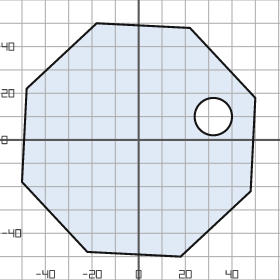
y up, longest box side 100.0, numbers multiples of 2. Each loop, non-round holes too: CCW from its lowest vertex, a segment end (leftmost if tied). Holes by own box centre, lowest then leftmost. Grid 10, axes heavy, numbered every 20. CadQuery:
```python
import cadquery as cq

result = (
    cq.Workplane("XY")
    .moveTo(18.0, -50.0)
    .lineTo(48.0, -22.0)
    .lineTo(50.0, 18.0)
    .lineTo(22.0, 48.0)
    .lineTo(-18.0, 50.0)
    .lineTo(-48.0, 22.0)
    .lineTo(-50.0, -18.0)
    .lineTo(-22.0, -48.0)
    .close()
    .moveTo(32.0, 10.0)
    .circle(8.0)
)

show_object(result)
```